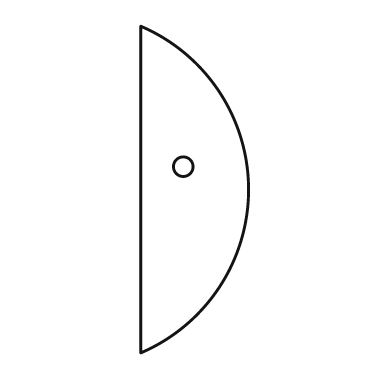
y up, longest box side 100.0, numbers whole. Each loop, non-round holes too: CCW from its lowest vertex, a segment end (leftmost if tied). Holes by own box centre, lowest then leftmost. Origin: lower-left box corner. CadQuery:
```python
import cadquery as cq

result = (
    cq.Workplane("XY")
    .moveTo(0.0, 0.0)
    .threePointArc((33.0, 50.0), (0.0, 100.0))
    .close()
    .moveTo(13.0, 57.0)
    .circle(3.0)
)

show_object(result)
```